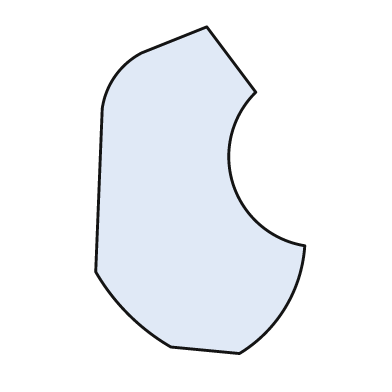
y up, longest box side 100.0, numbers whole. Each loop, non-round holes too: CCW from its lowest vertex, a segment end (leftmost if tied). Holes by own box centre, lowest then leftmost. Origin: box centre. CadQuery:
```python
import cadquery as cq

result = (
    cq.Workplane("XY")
    .moveTo(12.0, -50.0)
    .threePointArc((26.0, -36.0), (32.0, -17.0))
    .threePointArc((10.0, 2.0), (17.0, 30.0))
    .lineTo(2.0, 50.0)
    .lineTo(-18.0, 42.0)
    .threePointArc((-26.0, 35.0), (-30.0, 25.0))
    .lineTo(-32.0, -25.0)
    .threePointArc((-22.0, -38.0), (-9.0, -48.0))
    .close()
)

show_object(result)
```